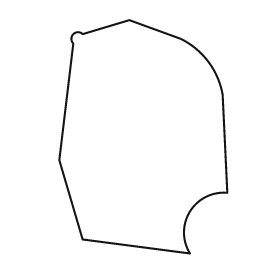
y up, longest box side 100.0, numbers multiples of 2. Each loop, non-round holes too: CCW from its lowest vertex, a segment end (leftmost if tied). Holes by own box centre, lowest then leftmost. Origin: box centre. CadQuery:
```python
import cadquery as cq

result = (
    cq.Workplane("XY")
    .moveTo(20.0, -50.0)
    .threePointArc((20.0, -32.0), (36.0, -24.0))
    .lineTo(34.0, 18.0)
    .threePointArc((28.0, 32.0), (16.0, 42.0))
    .lineTo(-6.0, 50.0)
    .lineTo(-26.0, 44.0)
    .threePointArc((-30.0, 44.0), (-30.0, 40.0))
    .lineTo(-36.0, -10.0)
    .lineTo(-26.0, -44.0)
    .close()
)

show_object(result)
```